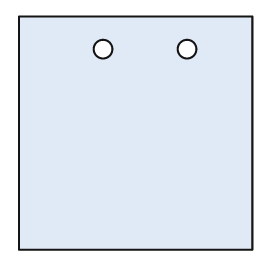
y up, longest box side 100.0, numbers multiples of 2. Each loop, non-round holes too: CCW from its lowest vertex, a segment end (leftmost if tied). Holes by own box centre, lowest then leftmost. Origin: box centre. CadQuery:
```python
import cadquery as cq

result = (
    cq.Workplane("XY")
    .moveTo(-50.0, -50.0)
    .lineTo(50.0, -50.0)
    .lineTo(50.0, 50.0)
    .lineTo(-50.0, 50.0)
    .close()
    .moveTo(-14.0, 36.0)
    .circle(4.0)
    .moveTo(22.0, 36.0)
    .circle(4.0)
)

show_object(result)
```